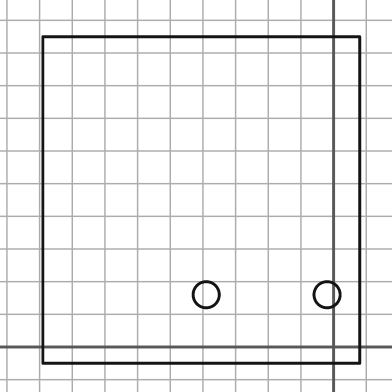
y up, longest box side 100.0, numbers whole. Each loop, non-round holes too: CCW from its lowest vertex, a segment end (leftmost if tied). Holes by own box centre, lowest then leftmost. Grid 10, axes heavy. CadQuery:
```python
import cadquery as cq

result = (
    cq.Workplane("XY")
    .moveTo(-89.0, -5.0)
    .lineTo(8.0, -5.0)
    .lineTo(8.0, 95.0)
    .lineTo(-89.0, 95.0)
    .close()
    .moveTo(-39.0, 16.0)
    .circle(4.0)
    .moveTo(-2.0, 16.0)
    .circle(4.0)
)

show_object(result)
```